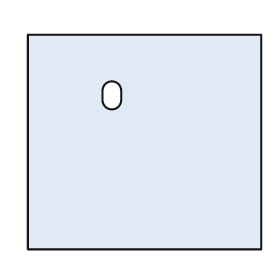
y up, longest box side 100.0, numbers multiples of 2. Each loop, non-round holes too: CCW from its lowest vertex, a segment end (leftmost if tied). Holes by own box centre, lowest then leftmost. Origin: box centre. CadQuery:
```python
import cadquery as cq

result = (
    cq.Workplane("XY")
    .moveTo(-50.0, -46.0)
    .lineTo(50.0, -46.0)
    .lineTo(50.0, 46.0)
    .lineTo(-50.0, 46.0)
    .close()
    .moveTo(-18.0, 18.0)
    .threePointArc((-14.0, 14.0), (-10.0, 18.0))
    .lineTo(-10.0, 22.0)
    .threePointArc((-14.0, 26.0), (-18.0, 22.0))
    .close()
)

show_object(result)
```